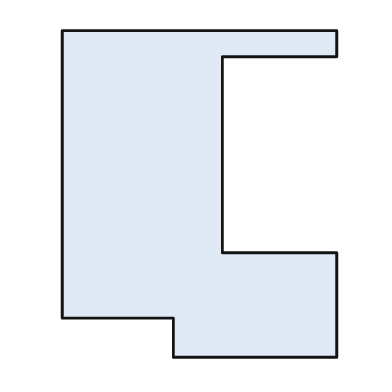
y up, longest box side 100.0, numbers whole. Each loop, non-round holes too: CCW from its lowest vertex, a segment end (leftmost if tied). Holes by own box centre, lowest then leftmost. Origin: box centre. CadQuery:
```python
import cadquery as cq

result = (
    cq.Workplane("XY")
    .moveTo(-8.0, -50.0)
    .lineTo(42.0, -50.0)
    .lineTo(42.0, -18.0)
    .lineTo(7.0, -18.0)
    .lineTo(7.0, 42.0)
    .lineTo(42.0, 42.0)
    .lineTo(42.0, 50.0)
    .lineTo(-42.0, 50.0)
    .lineTo(-42.0, -38.0)
    .lineTo(-8.0, -38.0)
    .close()
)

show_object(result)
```